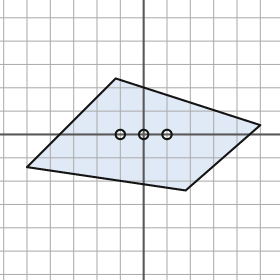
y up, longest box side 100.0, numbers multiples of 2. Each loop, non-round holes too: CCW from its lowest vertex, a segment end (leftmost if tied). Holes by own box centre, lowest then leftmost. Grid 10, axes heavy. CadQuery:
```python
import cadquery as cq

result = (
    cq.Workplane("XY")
    .moveTo(18.0, -24.0)
    .lineTo(50.0, 4.0)
    .lineTo(-12.0, 24.0)
    .lineTo(-50.0, -14.0)
    .close()
    .moveTo(-10.0, 0.0)
    .circle(2.0)
    .moveTo(0.0, 0.0)
    .circle(2.0)
    .moveTo(10.0, 0.0)
    .circle(2.0)
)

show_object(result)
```